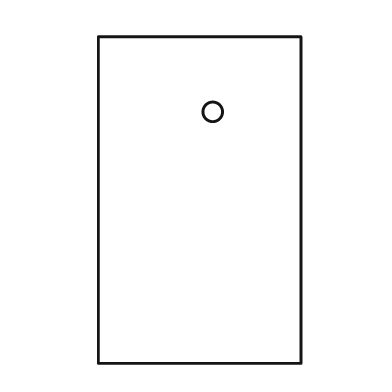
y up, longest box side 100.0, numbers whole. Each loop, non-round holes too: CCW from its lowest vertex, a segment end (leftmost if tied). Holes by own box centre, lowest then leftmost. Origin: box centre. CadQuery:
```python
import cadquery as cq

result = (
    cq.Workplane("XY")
    .moveTo(-31.0, -50.0)
    .lineTo(31.0, -50.0)
    .lineTo(31.0, 50.0)
    .lineTo(-31.0, 50.0)
    .close()
    .moveTo(4.0, 27.0)
    .circle(3.0)
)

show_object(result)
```